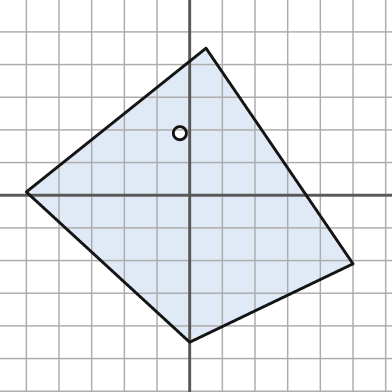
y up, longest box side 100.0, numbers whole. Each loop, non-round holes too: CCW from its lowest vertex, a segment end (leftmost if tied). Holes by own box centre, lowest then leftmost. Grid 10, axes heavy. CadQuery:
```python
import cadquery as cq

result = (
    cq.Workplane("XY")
    .moveTo(0.0, -45.0)
    .lineTo(50.0, -21.0)
    .lineTo(5.0, 45.0)
    .lineTo(-50.0, 1.0)
    .close()
    .moveTo(-3.0, 19.0)
    .circle(2.0)
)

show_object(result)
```